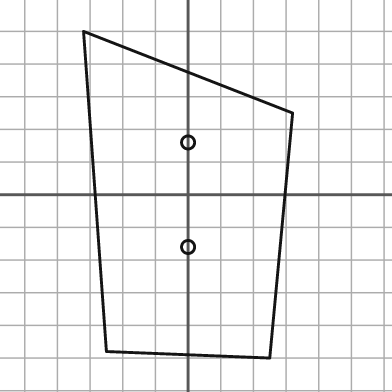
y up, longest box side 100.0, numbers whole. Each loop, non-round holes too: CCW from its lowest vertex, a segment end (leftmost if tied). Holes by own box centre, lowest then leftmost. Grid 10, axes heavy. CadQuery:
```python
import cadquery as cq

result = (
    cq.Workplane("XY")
    .moveTo(25.0, -50.0)
    .lineTo(32.0, 25.0)
    .lineTo(-32.0, 50.0)
    .lineTo(-25.0, -48.0)
    .close()
    .moveTo(0.0, -16.0)
    .circle(2.0)
    .moveTo(0.0, 16.0)
    .circle(2.0)
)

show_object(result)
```